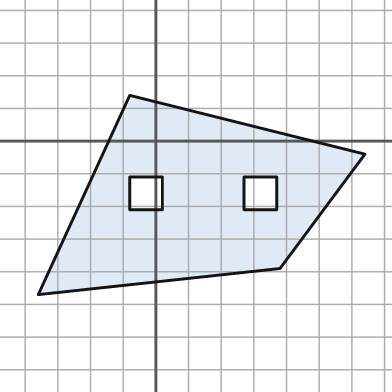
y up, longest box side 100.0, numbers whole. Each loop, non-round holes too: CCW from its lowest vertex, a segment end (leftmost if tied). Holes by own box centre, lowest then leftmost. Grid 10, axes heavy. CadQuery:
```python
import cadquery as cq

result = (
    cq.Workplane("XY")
    .moveTo(-36.0, -47.0)
    .lineTo(38.0, -39.0)
    .lineTo(64.0, -4.0)
    .lineTo(-8.0, 14.0)
    .close()
    .moveTo(-8.0, -21.0)
    .lineTo(2.0, -21.0)
    .lineTo(2.0, -11.0)
    .lineTo(-8.0, -11.0)
    .close()
    .moveTo(27.0, -21.0)
    .lineTo(37.0, -21.0)
    .lineTo(37.0, -11.0)
    .lineTo(27.0, -11.0)
    .close()
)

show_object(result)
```